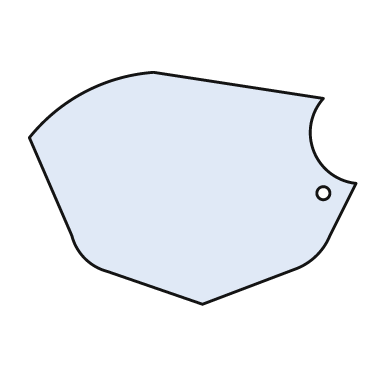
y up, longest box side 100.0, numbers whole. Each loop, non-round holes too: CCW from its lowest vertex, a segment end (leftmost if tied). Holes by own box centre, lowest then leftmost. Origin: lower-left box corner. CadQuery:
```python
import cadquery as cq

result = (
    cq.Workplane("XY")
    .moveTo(53.0, 0.0)
    .lineTo(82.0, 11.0)
    .threePointArc((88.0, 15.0), (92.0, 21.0))
    .lineTo(100.0, 37.0)
    .threePointArc((87.0, 47.0), (90.0, 63.0))
    .lineTo(38.0, 71.0)
    .threePointArc((17.0, 65.0), (0.0, 51.0))
    .lineTo(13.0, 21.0)
    .threePointArc((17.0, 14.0), (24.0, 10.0))
    .close()
    .moveTo(90.0, 34.0)
    .circle(2.0)
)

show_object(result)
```